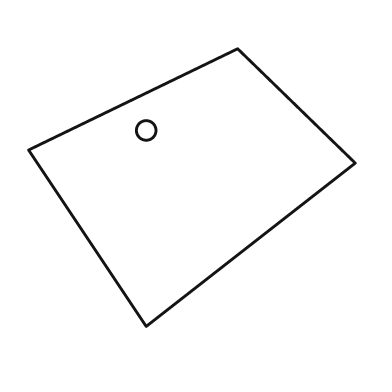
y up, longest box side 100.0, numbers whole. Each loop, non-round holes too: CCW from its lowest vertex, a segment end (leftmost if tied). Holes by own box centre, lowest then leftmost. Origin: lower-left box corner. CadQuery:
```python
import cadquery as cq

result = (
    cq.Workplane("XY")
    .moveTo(36.0, 0.0)
    .lineTo(100.0, 50.0)
    .lineTo(64.0, 85.0)
    .lineTo(0.0, 54.0)
    .close()
    .moveTo(36.0, 60.0)
    .circle(3.0)
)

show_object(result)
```